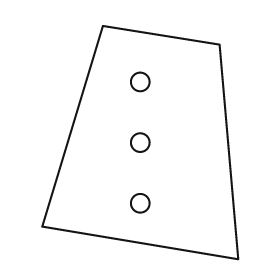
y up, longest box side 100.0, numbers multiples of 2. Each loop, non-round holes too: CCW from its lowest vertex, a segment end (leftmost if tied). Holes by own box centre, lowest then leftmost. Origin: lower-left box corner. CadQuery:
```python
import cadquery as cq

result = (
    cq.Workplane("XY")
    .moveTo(84.0, 0.0)
    .lineTo(76.0, 92.0)
    .lineTo(26.0, 100.0)
    .lineTo(0.0, 14.0)
    .close()
    .moveTo(42.0, 24.0)
    .circle(4.0)
    .moveTo(42.0, 50.0)
    .circle(4.0)
    .moveTo(42.0, 76.0)
    .circle(4.0)
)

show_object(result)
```